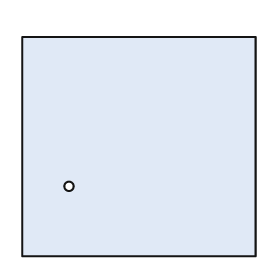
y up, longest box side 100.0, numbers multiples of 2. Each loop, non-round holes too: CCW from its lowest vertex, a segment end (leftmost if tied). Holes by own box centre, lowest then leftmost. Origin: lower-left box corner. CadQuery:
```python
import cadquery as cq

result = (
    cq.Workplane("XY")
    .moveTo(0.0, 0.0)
    .lineTo(100.0, 0.0)
    .lineTo(100.0, 94.0)
    .lineTo(0.0, 94.0)
    .close()
    .moveTo(20.0, 30.0)
    .circle(2.0)
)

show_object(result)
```